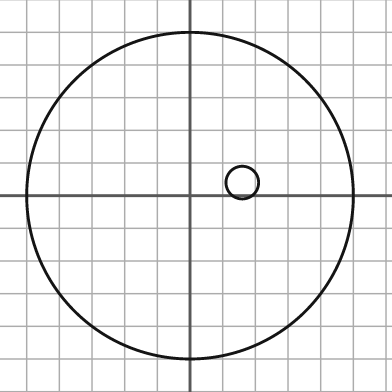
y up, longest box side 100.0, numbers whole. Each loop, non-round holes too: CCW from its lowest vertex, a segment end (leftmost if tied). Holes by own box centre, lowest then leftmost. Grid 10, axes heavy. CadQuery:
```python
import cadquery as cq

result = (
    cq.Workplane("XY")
    .moveTo(0.0, 0.0)
    .circle(50.0)
    .moveTo(16.0, 4.0)
    .circle(5.0)
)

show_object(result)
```